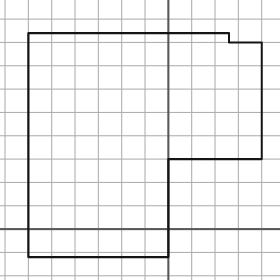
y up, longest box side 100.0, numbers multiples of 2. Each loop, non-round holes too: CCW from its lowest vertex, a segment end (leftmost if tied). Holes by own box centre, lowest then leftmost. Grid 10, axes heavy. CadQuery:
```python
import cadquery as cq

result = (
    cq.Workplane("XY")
    .moveTo(-60.0, -12.0)
    .lineTo(0.0, -12.0)
    .lineTo(0.0, 30.0)
    .lineTo(40.0, 30.0)
    .lineTo(40.0, 80.0)
    .lineTo(26.0, 80.0)
    .lineTo(26.0, 84.0)
    .lineTo(-60.0, 84.0)
    .close()
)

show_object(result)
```